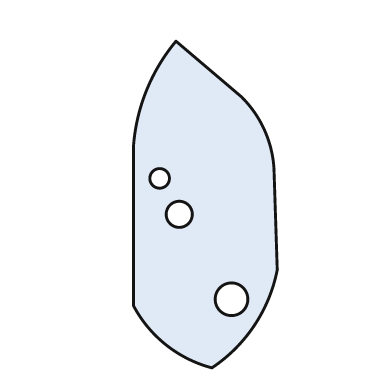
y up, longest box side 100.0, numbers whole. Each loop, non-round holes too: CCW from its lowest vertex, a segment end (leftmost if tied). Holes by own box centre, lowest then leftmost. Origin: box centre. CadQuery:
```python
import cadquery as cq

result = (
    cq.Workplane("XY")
    .moveTo(2.0, -50.0)
    .threePointArc((15.0, -37.0), (22.0, -20.0))
    .lineTo(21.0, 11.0)
    .threePointArc((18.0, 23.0), (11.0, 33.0))
    .lineTo(-9.0, 50.0)
    .threePointArc((-18.0, 35.0), (-22.0, 18.0))
    .lineTo(-22.0, -31.0)
    .threePointArc((-12.0, -43.0), (2.0, -50.0))
    .close()
    .moveTo(8.0, -29.0)
    .circle(5.0)
    .moveTo(-8.0, -3.0)
    .circle(4.0)
    .moveTo(-14.0, 8.0)
    .circle(3.0)
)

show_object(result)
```